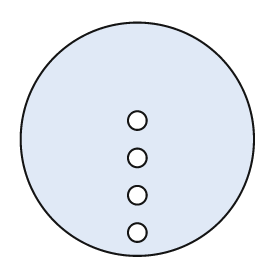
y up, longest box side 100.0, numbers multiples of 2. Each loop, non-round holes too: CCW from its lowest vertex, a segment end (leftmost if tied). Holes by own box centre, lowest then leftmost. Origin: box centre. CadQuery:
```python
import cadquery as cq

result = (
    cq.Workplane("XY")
    .moveTo(0.0, 0.0)
    .circle(50.0)
    .moveTo(0.0, -40.0)
    .circle(4.0)
    .moveTo(0.0, -24.0)
    .circle(4.0)
    .moveTo(0.0, -8.0)
    .circle(4.0)
    .moveTo(0.0, 8.0)
    .circle(4.0)
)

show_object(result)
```